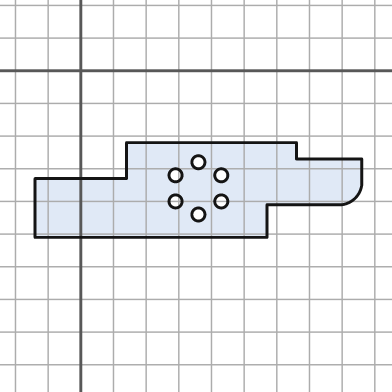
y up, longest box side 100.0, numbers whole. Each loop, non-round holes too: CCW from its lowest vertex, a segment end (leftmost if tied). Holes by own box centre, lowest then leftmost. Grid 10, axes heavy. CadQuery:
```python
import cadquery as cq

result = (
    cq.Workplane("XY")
    .moveTo(-14.0, -51.0)
    .lineTo(57.0, -51.0)
    .lineTo(57.0, -41.0)
    .lineTo(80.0, -41.0)
    .threePointArc((84.0, -39.0), (86.0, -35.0))
    .lineTo(86.0, -27.0)
    .lineTo(66.0, -27.0)
    .lineTo(66.0, -22.0)
    .lineTo(14.0, -22.0)
    .lineTo(14.0, -33.0)
    .lineTo(-14.0, -33.0)
    .close()
    .moveTo(36.0, -44.0)
    .circle(2.0)
    .moveTo(29.0, -40.0)
    .circle(2.0)
    .moveTo(43.0, -40.0)
    .circle(2.0)
    .moveTo(29.0, -32.0)
    .circle(2.0)
    .moveTo(43.0, -32.0)
    .circle(2.0)
    .moveTo(36.0, -28.0)
    .circle(2.0)
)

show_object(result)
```